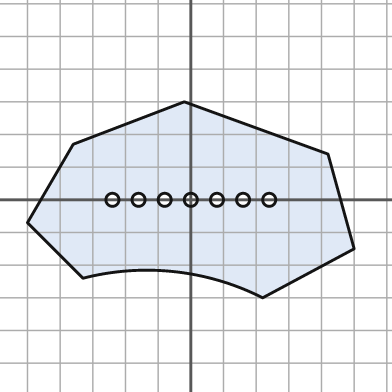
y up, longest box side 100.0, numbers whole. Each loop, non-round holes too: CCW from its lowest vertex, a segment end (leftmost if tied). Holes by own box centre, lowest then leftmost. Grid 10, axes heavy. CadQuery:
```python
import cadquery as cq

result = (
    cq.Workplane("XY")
    .moveTo(22.0, -30.0)
    .lineTo(50.0, -15.0)
    .lineTo(42.0, 14.0)
    .lineTo(-2.0, 30.0)
    .lineTo(-36.0, 17.0)
    .lineTo(-50.0, -7.0)
    .lineTo(-33.0, -24.0)
    .threePointArc((-5.0, -22.0), (22.0, -30.0))
    .close()
    .moveTo(-24.0, 0.0)
    .circle(2.0)
    .moveTo(-16.0, 0.0)
    .circle(2.0)
    .moveTo(-8.0, 0.0)
    .circle(2.0)
    .moveTo(0.0, 0.0)
    .circle(2.0)
    .moveTo(8.0, 0.0)
    .circle(2.0)
    .moveTo(16.0, 0.0)
    .circle(2.0)
    .moveTo(24.0, 0.0)
    .circle(2.0)
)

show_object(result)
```